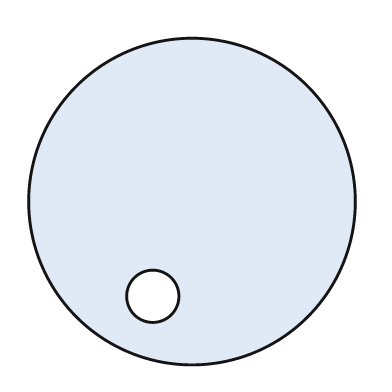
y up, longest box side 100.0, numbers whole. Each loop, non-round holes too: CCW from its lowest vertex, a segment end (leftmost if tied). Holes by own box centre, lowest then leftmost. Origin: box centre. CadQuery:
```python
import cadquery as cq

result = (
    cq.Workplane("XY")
    .moveTo(0.0, 0.0)
    .circle(50.0)
    .moveTo(-12.0, -29.0)
    .circle(8.0)
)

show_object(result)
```